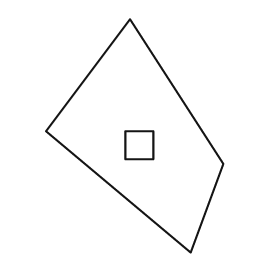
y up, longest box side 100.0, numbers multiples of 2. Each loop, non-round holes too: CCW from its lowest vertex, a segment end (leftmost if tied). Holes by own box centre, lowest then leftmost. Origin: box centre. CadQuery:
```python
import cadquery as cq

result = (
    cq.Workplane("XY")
    .moveTo(24.0, -50.0)
    .lineTo(38.0, -12.0)
    .lineTo(-2.0, 50.0)
    .lineTo(-38.0, 2.0)
    .close()
    .moveTo(-4.0, -10.0)
    .lineTo(8.0, -10.0)
    .lineTo(8.0, 2.0)
    .lineTo(-4.0, 2.0)
    .close()
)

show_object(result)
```